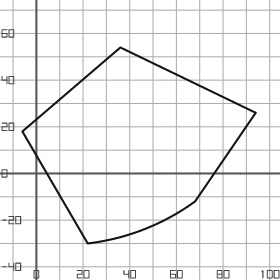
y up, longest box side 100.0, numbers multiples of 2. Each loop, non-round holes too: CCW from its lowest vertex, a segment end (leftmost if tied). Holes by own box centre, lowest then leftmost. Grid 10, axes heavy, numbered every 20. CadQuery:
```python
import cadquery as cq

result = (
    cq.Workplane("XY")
    .moveTo(22.0, -30.0)
    .threePointArc((46.0, -24.0), (68.0, -12.0))
    .lineTo(94.0, 26.0)
    .lineTo(36.0, 54.0)
    .lineTo(-6.0, 18.0)
    .close()
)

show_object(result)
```